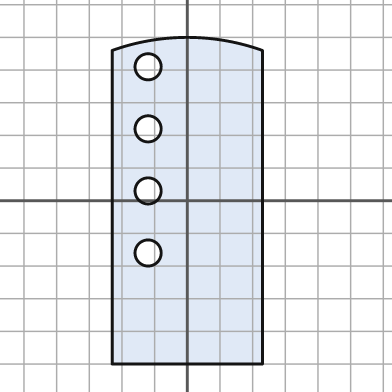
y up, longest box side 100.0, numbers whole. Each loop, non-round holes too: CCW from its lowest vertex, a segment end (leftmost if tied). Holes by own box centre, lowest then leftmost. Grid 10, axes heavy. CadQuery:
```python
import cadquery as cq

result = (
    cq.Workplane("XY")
    .moveTo(-23.0, -50.0)
    .lineTo(23.0, -50.0)
    .lineTo(23.0, 46.0)
    .threePointArc((0.0, 50.0), (-23.0, 46.0))
    .close()
    .moveTo(-12.0, -16.0)
    .circle(4.0)
    .moveTo(-12.0, 3.0)
    .circle(4.0)
    .moveTo(-12.0, 22.0)
    .circle(4.0)
    .moveTo(-12.0, 41.0)
    .circle(4.0)
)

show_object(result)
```